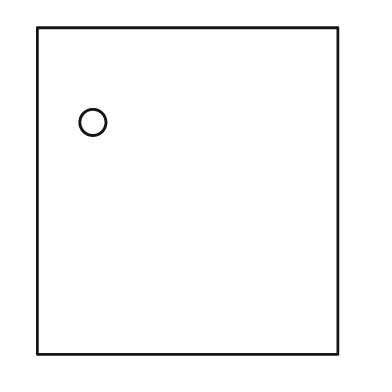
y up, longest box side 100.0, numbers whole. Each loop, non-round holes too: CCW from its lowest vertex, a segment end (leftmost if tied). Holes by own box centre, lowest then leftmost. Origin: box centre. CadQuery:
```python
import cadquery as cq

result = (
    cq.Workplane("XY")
    .moveTo(-46.0, -50.0)
    .lineTo(46.0, -50.0)
    .lineTo(46.0, 50.0)
    .lineTo(-46.0, 50.0)
    .close()
    .moveTo(-29.0, 21.0)
    .circle(4.0)
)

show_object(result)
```